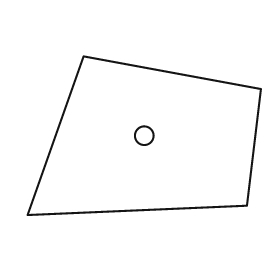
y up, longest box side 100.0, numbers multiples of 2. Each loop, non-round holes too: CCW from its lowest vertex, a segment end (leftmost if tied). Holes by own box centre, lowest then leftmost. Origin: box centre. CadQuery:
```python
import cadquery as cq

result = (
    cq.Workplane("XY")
    .moveTo(-50.0, -34.0)
    .lineTo(44.0, -30.0)
    .lineTo(50.0, 20.0)
    .lineTo(-26.0, 34.0)
    .close()
    .moveTo(0.0, 0.0)
    .circle(4.0)
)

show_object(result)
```